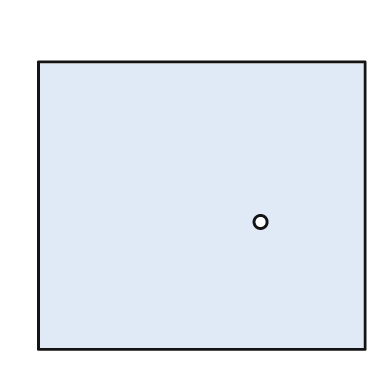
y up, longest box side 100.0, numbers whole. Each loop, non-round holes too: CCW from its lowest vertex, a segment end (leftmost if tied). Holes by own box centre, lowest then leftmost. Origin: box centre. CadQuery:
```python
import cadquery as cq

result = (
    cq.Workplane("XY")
    .moveTo(-50.0, -44.0)
    .lineTo(50.0, -44.0)
    .lineTo(50.0, 44.0)
    .lineTo(-50.0, 44.0)
    .close()
    .moveTo(18.0, -5.0)
    .circle(2.0)
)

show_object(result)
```